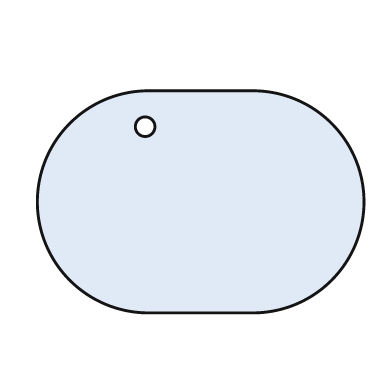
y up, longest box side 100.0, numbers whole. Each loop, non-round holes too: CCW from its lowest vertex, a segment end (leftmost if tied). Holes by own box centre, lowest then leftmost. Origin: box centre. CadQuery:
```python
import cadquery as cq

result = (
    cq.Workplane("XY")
    .moveTo(-16.0, -34.0)
    .lineTo(16.0, -34.0)
    .threePointArc((50.0, 0.0), (16.0, 34.0))
    .lineTo(-16.0, 34.0)
    .threePointArc((-50.0, 0.0), (-16.0, -34.0))
    .close()
    .moveTo(-17.0, 23.0)
    .circle(3.0)
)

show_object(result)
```